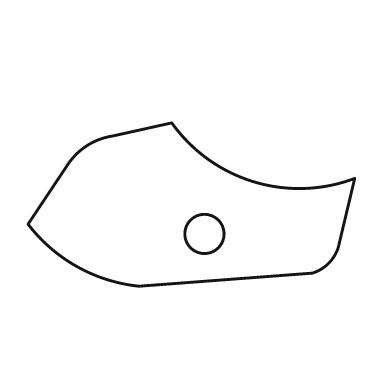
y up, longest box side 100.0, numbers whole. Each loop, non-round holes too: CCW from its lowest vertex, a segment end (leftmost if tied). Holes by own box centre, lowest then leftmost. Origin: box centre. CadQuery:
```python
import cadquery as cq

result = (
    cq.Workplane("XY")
    .moveTo(-16.0, -25.0)
    .lineTo(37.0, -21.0)
    .threePointArc((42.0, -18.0), (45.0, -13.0))
    .lineTo(50.0, 8.0)
    .threePointArc((19.0, 7.0), (-6.0, 25.0))
    .lineTo(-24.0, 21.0)
    .threePointArc((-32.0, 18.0), (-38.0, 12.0))
    .lineTo(-50.0, -6.0)
    .threePointArc((-35.0, -19.0), (-16.0, -25.0))
    .close()
    .moveTo(4.0, -9.0)
    .circle(6.0)
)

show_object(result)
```